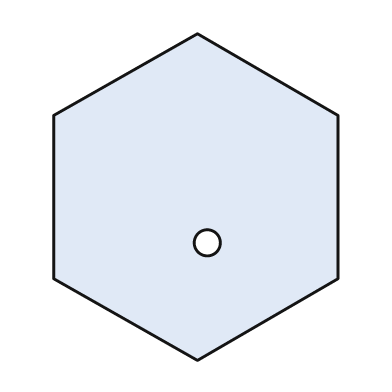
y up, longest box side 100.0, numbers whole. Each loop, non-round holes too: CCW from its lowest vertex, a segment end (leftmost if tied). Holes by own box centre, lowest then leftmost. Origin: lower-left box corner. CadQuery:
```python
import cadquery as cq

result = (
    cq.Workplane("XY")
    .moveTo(44.0, 0.0)
    .lineTo(87.0, 25.0)
    .lineTo(87.0, 75.0)
    .lineTo(44.0, 100.0)
    .lineTo(0.0, 75.0)
    .lineTo(0.0, 25.0)
    .close()
    .moveTo(47.0, 36.0)
    .circle(4.0)
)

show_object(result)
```